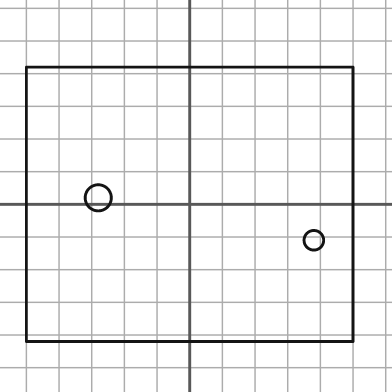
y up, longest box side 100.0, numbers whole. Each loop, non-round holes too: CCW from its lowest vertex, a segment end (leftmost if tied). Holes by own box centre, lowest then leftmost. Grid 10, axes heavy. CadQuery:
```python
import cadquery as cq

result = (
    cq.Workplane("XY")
    .moveTo(-50.0, -42.0)
    .lineTo(50.0, -42.0)
    .lineTo(50.0, 42.0)
    .lineTo(-50.0, 42.0)
    .close()
    .moveTo(38.0, -11.0)
    .circle(3.0)
    .moveTo(-28.0, 2.0)
    .circle(4.0)
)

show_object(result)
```